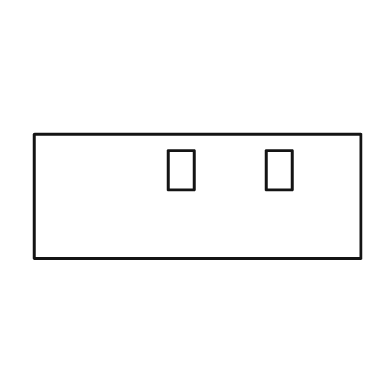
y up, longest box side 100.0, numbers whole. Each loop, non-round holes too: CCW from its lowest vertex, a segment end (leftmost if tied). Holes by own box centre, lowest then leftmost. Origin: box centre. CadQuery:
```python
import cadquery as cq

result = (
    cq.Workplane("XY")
    .moveTo(-50.0, -19.0)
    .lineTo(50.0, -19.0)
    .lineTo(50.0, 19.0)
    .lineTo(-50.0, 19.0)
    .close()
    .moveTo(-9.0, 2.0)
    .lineTo(-1.0, 2.0)
    .lineTo(-1.0, 14.0)
    .lineTo(-9.0, 14.0)
    .close()
    .moveTo(21.0, 2.0)
    .lineTo(29.0, 2.0)
    .lineTo(29.0, 14.0)
    .lineTo(21.0, 14.0)
    .close()
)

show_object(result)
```